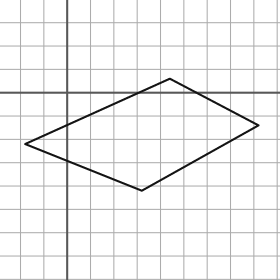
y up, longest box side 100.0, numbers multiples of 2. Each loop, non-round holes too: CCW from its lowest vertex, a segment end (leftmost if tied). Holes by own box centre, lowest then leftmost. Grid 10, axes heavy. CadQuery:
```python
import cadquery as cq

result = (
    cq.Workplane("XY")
    .moveTo(32.0, -42.0)
    .lineTo(82.0, -14.0)
    .lineTo(44.0, 6.0)
    .lineTo(-18.0, -22.0)
    .close()
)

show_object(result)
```